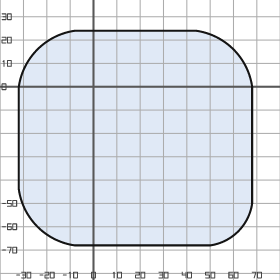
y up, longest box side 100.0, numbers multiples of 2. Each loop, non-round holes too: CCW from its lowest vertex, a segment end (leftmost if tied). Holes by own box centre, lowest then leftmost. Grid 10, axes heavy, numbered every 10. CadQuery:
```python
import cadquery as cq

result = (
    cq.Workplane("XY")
    .moveTo(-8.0, -68.0)
    .lineTo(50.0, -68.0)
    .threePointArc((62.0, -62.0), (68.0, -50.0))
    .lineTo(68.0, 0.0)
    .threePointArc((60.0, 16.0), (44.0, 24.0))
    .lineTo(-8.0, 24.0)
    .threePointArc((-24.0, 16.0), (-32.0, 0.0))
    .lineTo(-32.0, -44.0)
    .threePointArc((-24.0, -60.0), (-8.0, -68.0))
    .close()
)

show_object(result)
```